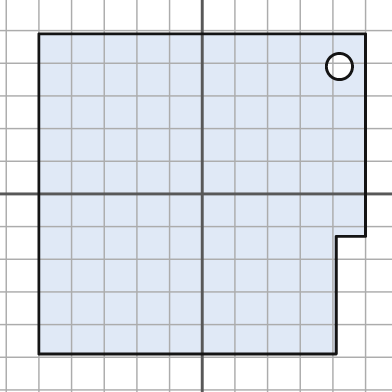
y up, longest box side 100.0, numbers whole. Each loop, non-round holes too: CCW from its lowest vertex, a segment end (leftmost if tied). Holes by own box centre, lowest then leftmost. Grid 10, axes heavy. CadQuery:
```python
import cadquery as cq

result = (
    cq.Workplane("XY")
    .moveTo(-50.0, -49.0)
    .lineTo(41.0, -49.0)
    .lineTo(41.0, -13.0)
    .lineTo(50.0, -13.0)
    .lineTo(50.0, 49.0)
    .lineTo(-50.0, 49.0)
    .close()
    .moveTo(42.0, 39.0)
    .circle(4.0)
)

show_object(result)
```